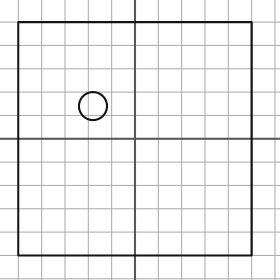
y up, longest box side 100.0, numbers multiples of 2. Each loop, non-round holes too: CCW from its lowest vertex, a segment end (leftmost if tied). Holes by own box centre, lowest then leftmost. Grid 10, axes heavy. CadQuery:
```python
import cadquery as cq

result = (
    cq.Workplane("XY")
    .moveTo(-50.0, -50.0)
    .lineTo(50.0, -50.0)
    .lineTo(50.0, 50.0)
    .lineTo(-50.0, 50.0)
    .close()
    .moveTo(-18.0, 14.0)
    .circle(6.0)
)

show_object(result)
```